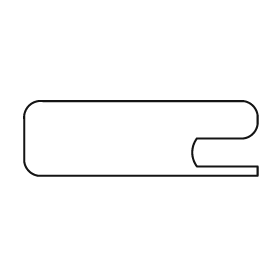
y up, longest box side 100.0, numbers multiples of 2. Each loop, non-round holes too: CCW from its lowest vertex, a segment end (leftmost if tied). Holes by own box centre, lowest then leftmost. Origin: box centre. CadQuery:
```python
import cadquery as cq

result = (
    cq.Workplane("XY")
    .moveTo(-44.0, -16.0)
    .lineTo(50.0, -16.0)
    .lineTo(50.0, -12.0)
    .lineTo(24.0, -12.0)
    .threePointArc((22.0, -6.0), (24.0, 0.0))
    .lineTo(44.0, 0.0)
    .threePointArc((48.0, 2.0), (50.0, 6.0))
    .lineTo(50.0, 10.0)
    .threePointArc((48.0, 14.0), (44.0, 16.0))
    .lineTo(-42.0, 16.0)
    .threePointArc((-48.0, 14.0), (-50.0, 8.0))
    .lineTo(-50.0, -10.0)
    .threePointArc((-48.0, -14.0), (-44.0, -16.0))
    .close()
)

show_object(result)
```